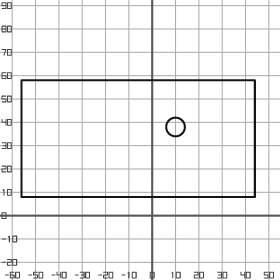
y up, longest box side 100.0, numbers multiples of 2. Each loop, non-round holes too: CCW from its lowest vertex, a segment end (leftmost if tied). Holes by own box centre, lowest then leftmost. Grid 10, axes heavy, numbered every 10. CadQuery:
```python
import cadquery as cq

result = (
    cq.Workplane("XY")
    .moveTo(-56.0, 8.0)
    .lineTo(44.0, 8.0)
    .lineTo(44.0, 58.0)
    .lineTo(-56.0, 58.0)
    .close()
    .moveTo(10.0, 38.0)
    .circle(4.0)
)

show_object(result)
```